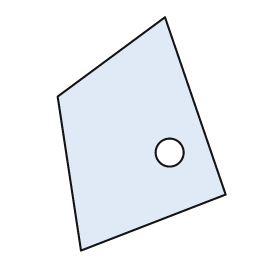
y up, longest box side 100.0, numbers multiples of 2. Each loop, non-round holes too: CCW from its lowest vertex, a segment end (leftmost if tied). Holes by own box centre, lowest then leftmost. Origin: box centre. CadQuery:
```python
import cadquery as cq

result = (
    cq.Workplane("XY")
    .moveTo(-26.0, -50.0)
    .lineTo(36.0, -26.0)
    .lineTo(10.0, 50.0)
    .lineTo(-36.0, 16.0)
    .close()
    .moveTo(12.0, -8.0)
    .circle(6.0)
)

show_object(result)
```